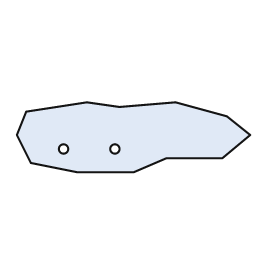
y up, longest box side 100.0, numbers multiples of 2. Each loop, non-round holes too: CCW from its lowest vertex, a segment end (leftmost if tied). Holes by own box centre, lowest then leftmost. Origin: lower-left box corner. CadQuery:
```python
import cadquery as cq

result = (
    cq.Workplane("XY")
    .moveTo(26.0, 0.0)
    .lineTo(50.0, 0.0)
    .lineTo(64.0, 6.0)
    .lineTo(88.0, 6.0)
    .lineTo(100.0, 16.0)
    .lineTo(90.0, 24.0)
    .lineTo(68.0, 30.0)
    .lineTo(44.0, 28.0)
    .lineTo(30.0, 30.0)
    .lineTo(4.0, 26.0)
    .lineTo(0.0, 16.0)
    .lineTo(6.0, 4.0)
    .close()
    .moveTo(20.0, 10.0)
    .circle(2.0)
    .moveTo(42.0, 10.0)
    .circle(2.0)
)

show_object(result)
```